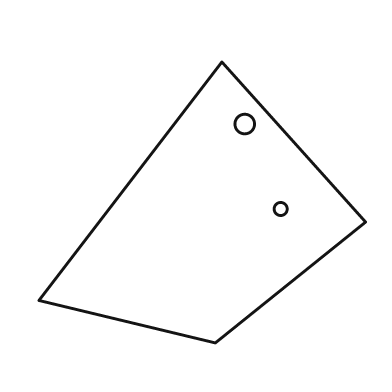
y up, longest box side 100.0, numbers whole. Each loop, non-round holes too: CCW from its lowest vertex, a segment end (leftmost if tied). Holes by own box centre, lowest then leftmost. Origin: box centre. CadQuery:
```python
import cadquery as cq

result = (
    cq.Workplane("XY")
    .moveTo(4.0, -43.0)
    .lineTo(50.0, -6.0)
    .lineTo(6.0, 43.0)
    .lineTo(-50.0, -30.0)
    .close()
    .moveTo(24.0, -2.0)
    .circle(2.0)
    .moveTo(13.0, 24.0)
    .circle(3.0)
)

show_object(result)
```